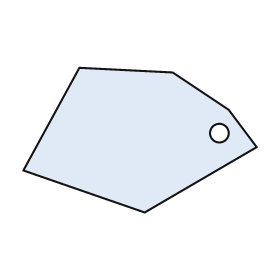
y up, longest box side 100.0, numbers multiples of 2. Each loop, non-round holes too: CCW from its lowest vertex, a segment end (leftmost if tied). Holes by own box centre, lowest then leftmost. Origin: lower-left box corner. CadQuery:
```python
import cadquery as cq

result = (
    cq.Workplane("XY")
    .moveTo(52.0, 0.0)
    .lineTo(100.0, 28.0)
    .lineTo(88.0, 44.0)
    .lineTo(64.0, 60.0)
    .lineTo(24.0, 62.0)
    .lineTo(0.0, 18.0)
    .close()
    .moveTo(84.0, 34.0)
    .circle(4.0)
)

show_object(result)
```